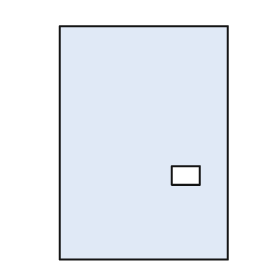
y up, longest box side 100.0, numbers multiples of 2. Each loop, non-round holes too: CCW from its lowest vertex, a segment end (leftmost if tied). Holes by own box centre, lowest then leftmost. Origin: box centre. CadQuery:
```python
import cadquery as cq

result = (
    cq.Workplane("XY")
    .moveTo(-36.0, -50.0)
    .lineTo(36.0, -50.0)
    .lineTo(36.0, 50.0)
    .lineTo(-36.0, 50.0)
    .close()
    .moveTo(12.0, -18.0)
    .lineTo(24.0, -18.0)
    .lineTo(24.0, -10.0)
    .lineTo(12.0, -10.0)
    .close()
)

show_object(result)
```